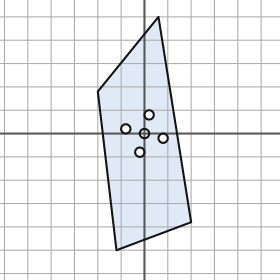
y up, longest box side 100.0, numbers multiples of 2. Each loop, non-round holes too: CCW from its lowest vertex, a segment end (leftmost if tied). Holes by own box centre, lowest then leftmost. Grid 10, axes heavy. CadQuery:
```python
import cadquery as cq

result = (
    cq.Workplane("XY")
    .moveTo(-12.0, -50.0)
    .lineTo(20.0, -38.0)
    .lineTo(6.0, 50.0)
    .lineTo(-20.0, 18.0)
    .close()
    .moveTo(-2.0, -8.0)
    .circle(2.0)
    .moveTo(8.0, -2.0)
    .circle(2.0)
    .moveTo(0.0, 0.0)
    .circle(2.0)
    .moveTo(-8.0, 2.0)
    .circle(2.0)
    .moveTo(2.0, 8.0)
    .circle(2.0)
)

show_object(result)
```